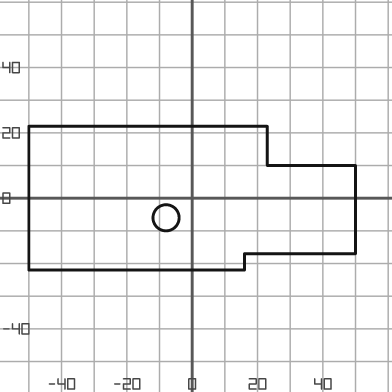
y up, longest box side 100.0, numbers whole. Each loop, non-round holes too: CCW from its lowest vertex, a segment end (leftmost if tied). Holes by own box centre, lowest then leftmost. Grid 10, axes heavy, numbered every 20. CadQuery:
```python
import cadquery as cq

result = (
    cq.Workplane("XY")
    .moveTo(-50.0, -22.0)
    .lineTo(16.0, -22.0)
    .lineTo(16.0, -17.0)
    .lineTo(50.0, -17.0)
    .lineTo(50.0, 10.0)
    .lineTo(23.0, 10.0)
    .lineTo(23.0, 22.0)
    .lineTo(-50.0, 22.0)
    .close()
    .moveTo(-8.0, -6.0)
    .circle(4.0)
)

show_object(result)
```